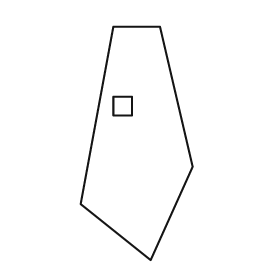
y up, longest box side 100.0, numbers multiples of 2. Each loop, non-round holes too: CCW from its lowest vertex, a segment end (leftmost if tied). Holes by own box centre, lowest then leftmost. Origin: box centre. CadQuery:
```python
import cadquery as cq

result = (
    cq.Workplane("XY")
    .moveTo(6.0, -50.0)
    .lineTo(24.0, -10.0)
    .lineTo(10.0, 50.0)
    .lineTo(-10.0, 50.0)
    .lineTo(-24.0, -26.0)
    .close()
    .moveTo(-10.0, 12.0)
    .lineTo(-2.0, 12.0)
    .lineTo(-2.0, 20.0)
    .lineTo(-10.0, 20.0)
    .close()
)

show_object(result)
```